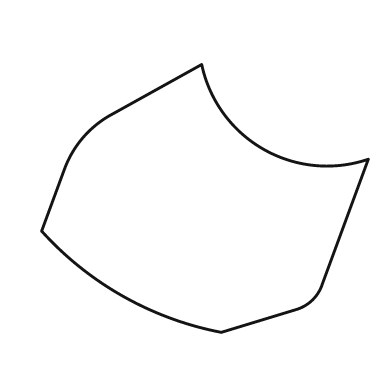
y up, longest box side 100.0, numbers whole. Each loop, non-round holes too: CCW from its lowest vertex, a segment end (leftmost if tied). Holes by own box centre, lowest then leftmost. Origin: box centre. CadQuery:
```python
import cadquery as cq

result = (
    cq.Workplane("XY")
    .moveTo(5.0, -41.0)
    .lineTo(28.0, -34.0)
    .threePointArc((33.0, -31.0), (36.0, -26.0))
    .lineTo(50.0, 12.0)
    .threePointArc((18.0, 15.0), (-1.0, 41.0))
    .lineTo(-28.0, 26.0)
    .threePointArc((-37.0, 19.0), (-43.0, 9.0))
    .lineTo(-50.0, -10.0)
    .threePointArc((-25.0, -30.0), (5.0, -41.0))
    .close()
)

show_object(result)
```